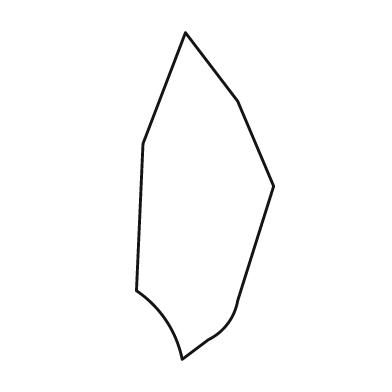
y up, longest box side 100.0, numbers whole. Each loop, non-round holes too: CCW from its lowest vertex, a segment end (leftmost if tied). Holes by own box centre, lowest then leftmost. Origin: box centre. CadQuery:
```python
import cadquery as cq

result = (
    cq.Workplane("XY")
    .moveTo(-7.0, -50.0)
    .lineTo(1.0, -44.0)
    .threePointArc((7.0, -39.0), (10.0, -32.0))
    .lineTo(21.0, 3.0)
    .lineTo(10.0, 29.0)
    .lineTo(-6.0, 50.0)
    .lineTo(-19.0, 16.0)
    .lineTo(-21.0, -29.0)
    .threePointArc((-12.0, -38.0), (-7.0, -50.0))
    .close()
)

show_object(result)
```